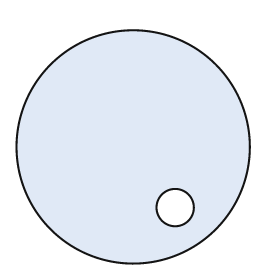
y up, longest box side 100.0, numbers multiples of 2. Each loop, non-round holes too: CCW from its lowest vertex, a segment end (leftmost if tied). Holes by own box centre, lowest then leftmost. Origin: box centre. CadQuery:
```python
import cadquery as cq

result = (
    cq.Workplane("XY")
    .moveTo(0.0, 0.0)
    .circle(50.0)
    .moveTo(18.0, -26.0)
    .circle(8.0)
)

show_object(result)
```